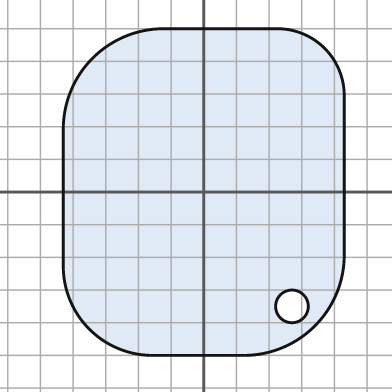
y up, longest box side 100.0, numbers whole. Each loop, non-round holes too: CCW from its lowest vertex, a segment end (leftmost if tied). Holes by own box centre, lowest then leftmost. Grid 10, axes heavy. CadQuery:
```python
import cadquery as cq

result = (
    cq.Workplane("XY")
    .moveTo(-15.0, -50.0)
    .lineTo(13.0, -50.0)
    .threePointArc((34.0, -41.0), (43.0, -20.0))
    .lineTo(43.0, 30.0)
    .threePointArc((37.0, 44.0), (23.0, 50.0))
    .lineTo(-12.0, 50.0)
    .threePointArc((-34.0, 41.0), (-43.0, 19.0))
    .lineTo(-43.0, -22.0)
    .threePointArc((-35.0, -42.0), (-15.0, -50.0))
    .close()
    .moveTo(27.0, -35.0)
    .circle(5.0)
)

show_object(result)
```